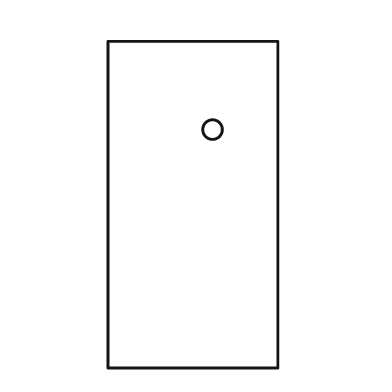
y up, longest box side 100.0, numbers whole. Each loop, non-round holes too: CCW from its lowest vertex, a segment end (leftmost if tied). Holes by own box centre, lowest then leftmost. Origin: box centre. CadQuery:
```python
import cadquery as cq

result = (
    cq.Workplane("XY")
    .moveTo(-26.0, -50.0)
    .lineTo(26.0, -50.0)
    .lineTo(26.0, 50.0)
    .lineTo(-26.0, 50.0)
    .close()
    .moveTo(6.0, 23.0)
    .circle(3.0)
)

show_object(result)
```